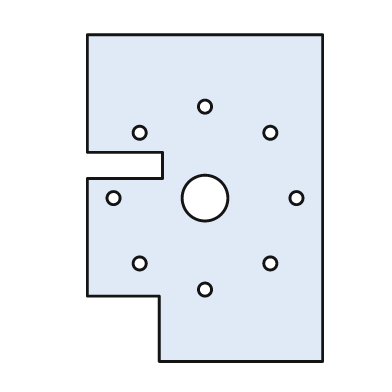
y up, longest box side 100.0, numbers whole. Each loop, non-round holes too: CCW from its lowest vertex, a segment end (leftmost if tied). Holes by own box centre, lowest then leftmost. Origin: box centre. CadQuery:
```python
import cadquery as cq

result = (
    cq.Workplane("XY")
    .moveTo(-14.0, -50.0)
    .lineTo(36.0, -50.0)
    .lineTo(36.0, 50.0)
    .lineTo(-36.0, 50.0)
    .lineTo(-36.0, 14.0)
    .lineTo(-13.0, 14.0)
    .lineTo(-13.0, 6.0)
    .lineTo(-36.0, 6.0)
    .lineTo(-36.0, -30.0)
    .lineTo(-14.0, -30.0)
    .close()
    .moveTo(0.0, -28.0)
    .circle(2.0)
    .moveTo(-20.0, -20.0)
    .circle(2.0)
    .moveTo(20.0, -20.0)
    .circle(2.0)
    .moveTo(-28.0, 0.0)
    .circle(2.0)
    .moveTo(0.0, 0.0)
    .circle(7.0)
    .moveTo(28.0, 0.0)
    .circle(2.0)
    .moveTo(-20.0, 20.0)
    .circle(2.0)
    .moveTo(20.0, 20.0)
    .circle(2.0)
    .moveTo(0.0, 28.0)
    .circle(2.0)
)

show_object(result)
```